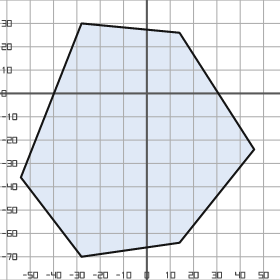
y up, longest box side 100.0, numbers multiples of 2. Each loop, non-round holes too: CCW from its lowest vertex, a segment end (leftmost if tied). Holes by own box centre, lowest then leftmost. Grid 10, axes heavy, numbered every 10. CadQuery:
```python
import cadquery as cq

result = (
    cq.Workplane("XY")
    .moveTo(-28.0, -70.0)
    .lineTo(14.0, -64.0)
    .lineTo(46.0, -24.0)
    .lineTo(14.0, 26.0)
    .lineTo(-28.0, 30.0)
    .lineTo(-54.0, -36.0)
    .close()
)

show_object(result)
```